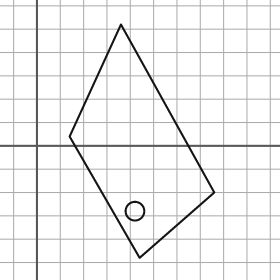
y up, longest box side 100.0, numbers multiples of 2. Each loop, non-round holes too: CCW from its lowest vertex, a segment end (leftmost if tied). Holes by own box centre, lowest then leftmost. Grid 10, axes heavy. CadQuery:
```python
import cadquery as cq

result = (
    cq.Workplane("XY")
    .moveTo(44.0, -48.0)
    .lineTo(76.0, -20.0)
    .lineTo(36.0, 52.0)
    .lineTo(14.0, 4.0)
    .close()
    .moveTo(42.0, -28.0)
    .circle(4.0)
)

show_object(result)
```